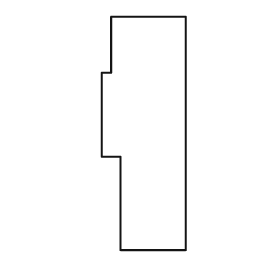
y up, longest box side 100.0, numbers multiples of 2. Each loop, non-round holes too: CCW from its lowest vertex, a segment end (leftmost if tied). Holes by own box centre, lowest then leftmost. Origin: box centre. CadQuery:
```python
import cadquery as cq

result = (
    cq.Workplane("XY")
    .moveTo(-10.0, -50.0)
    .lineTo(18.0, -50.0)
    .lineTo(18.0, 50.0)
    .lineTo(-14.0, 50.0)
    .lineTo(-14.0, 26.0)
    .lineTo(-18.0, 26.0)
    .lineTo(-18.0, -10.0)
    .lineTo(-10.0, -10.0)
    .close()
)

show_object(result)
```